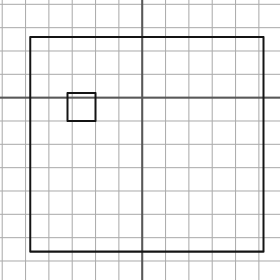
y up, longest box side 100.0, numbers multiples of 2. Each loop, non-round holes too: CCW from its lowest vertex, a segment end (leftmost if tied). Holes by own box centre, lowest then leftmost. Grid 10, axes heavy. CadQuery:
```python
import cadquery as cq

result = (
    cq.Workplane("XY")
    .moveTo(-48.0, -66.0)
    .lineTo(52.0, -66.0)
    .lineTo(52.0, 26.0)
    .lineTo(-48.0, 26.0)
    .close()
    .moveTo(-32.0, -10.0)
    .lineTo(-20.0, -10.0)
    .lineTo(-20.0, 2.0)
    .lineTo(-32.0, 2.0)
    .close()
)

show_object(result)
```